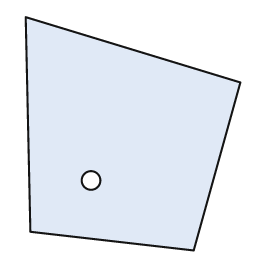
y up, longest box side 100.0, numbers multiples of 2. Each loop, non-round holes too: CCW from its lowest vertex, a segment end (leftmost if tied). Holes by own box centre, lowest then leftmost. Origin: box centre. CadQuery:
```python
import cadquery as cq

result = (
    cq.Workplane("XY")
    .moveTo(26.0, -50.0)
    .lineTo(46.0, 22.0)
    .lineTo(-46.0, 50.0)
    .lineTo(-44.0, -42.0)
    .close()
    .moveTo(-18.0, -20.0)
    .circle(4.0)
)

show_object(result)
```